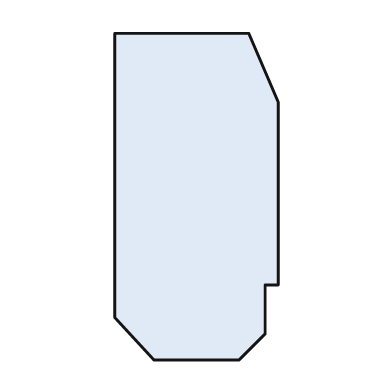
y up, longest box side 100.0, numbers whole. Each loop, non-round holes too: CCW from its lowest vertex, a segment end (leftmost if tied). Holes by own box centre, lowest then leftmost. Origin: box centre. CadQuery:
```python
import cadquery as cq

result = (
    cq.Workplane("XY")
    .moveTo(-13.0, -50.0)
    .lineTo(13.0, -50.0)
    .lineTo(21.0, -42.0)
    .lineTo(21.0, -27.0)
    .lineTo(25.0, -27.0)
    .lineTo(25.0, 29.0)
    .lineTo(16.0, 50.0)
    .lineTo(-25.0, 50.0)
    .lineTo(-25.0, -37.0)
    .close()
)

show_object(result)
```